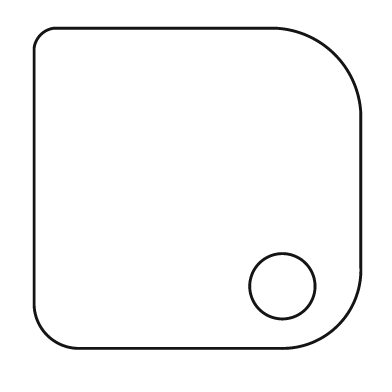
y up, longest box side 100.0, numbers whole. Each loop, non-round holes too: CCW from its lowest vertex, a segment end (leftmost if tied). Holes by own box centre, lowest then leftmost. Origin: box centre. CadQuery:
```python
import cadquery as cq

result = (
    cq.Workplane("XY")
    .moveTo(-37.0, -49.0)
    .lineTo(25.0, -49.0)
    .threePointArc((43.0, -42.0), (50.0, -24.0))
    .lineTo(50.0, 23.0)
    .threePointArc((42.0, 41.0), (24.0, 49.0))
    .lineTo(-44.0, 49.0)
    .threePointArc((-48.0, 47.0), (-50.0, 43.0))
    .lineTo(-50.0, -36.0)
    .threePointArc((-46.0, -45.0), (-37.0, -49.0))
    .close()
    .moveTo(26.0, -30.0)
    .circle(10.0)
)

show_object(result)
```